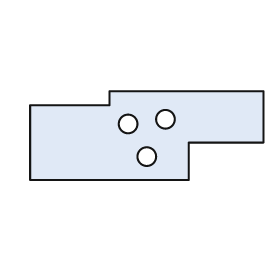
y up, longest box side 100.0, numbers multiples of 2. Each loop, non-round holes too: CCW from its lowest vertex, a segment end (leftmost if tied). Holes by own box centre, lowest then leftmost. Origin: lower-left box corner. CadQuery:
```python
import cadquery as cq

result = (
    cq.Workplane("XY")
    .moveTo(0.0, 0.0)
    .lineTo(68.0, 0.0)
    .lineTo(68.0, 16.0)
    .lineTo(100.0, 16.0)
    .lineTo(100.0, 38.0)
    .lineTo(34.0, 38.0)
    .lineTo(34.0, 32.0)
    .lineTo(0.0, 32.0)
    .close()
    .moveTo(50.0, 10.0)
    .circle(4.0)
    .moveTo(42.0, 24.0)
    .circle(4.0)
    .moveTo(58.0, 26.0)
    .circle(4.0)
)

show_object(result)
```